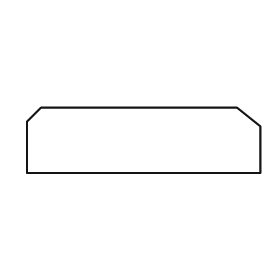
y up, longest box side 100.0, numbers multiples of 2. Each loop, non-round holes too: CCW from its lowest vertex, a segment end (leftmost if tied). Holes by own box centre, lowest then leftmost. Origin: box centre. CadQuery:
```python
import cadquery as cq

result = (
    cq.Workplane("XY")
    .moveTo(-50.0, -14.0)
    .lineTo(50.0, -14.0)
    .lineTo(50.0, 6.0)
    .lineTo(40.0, 14.0)
    .lineTo(-44.0, 14.0)
    .lineTo(-50.0, 8.0)
    .close()
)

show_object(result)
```